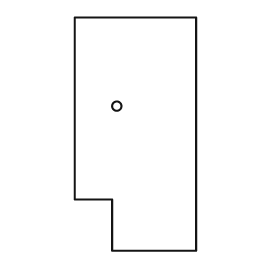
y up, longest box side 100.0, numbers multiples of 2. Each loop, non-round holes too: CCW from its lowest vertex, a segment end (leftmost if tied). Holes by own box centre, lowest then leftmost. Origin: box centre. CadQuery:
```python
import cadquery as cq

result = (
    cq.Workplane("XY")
    .moveTo(-10.0, -50.0)
    .lineTo(26.0, -50.0)
    .lineTo(26.0, 50.0)
    .lineTo(-26.0, 50.0)
    .lineTo(-26.0, -28.0)
    .lineTo(-10.0, -28.0)
    .close()
    .moveTo(-8.0, 12.0)
    .circle(2.0)
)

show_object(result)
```